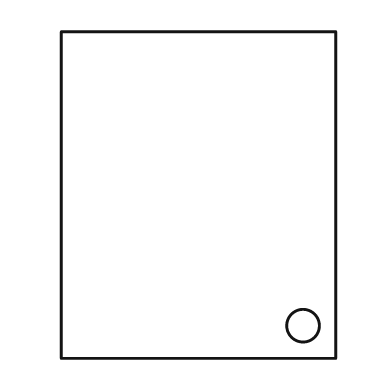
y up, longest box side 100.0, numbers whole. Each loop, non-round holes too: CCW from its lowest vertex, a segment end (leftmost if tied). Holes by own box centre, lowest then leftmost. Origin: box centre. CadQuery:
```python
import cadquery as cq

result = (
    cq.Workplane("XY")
    .moveTo(-42.0, -50.0)
    .lineTo(42.0, -50.0)
    .lineTo(42.0, 50.0)
    .lineTo(-42.0, 50.0)
    .close()
    .moveTo(32.0, -40.0)
    .circle(5.0)
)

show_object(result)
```